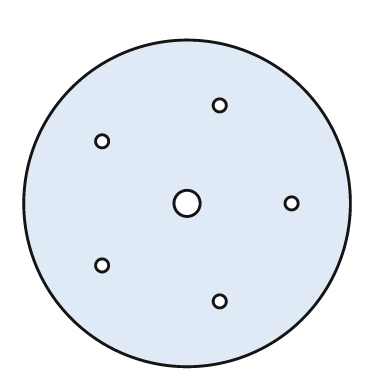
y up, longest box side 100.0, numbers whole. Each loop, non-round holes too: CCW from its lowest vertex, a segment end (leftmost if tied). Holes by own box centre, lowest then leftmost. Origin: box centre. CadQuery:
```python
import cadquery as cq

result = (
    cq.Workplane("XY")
    .moveTo(0.0, 0.0)
    .circle(50.0)
    .moveTo(10.0, -30.0)
    .circle(2.0)
    .moveTo(-26.0, -19.0)
    .circle(2.0)
    .moveTo(0.0, 0.0)
    .circle(4.0)
    .moveTo(32.0, 0.0)
    .circle(2.0)
    .moveTo(-26.0, 19.0)
    .circle(2.0)
    .moveTo(10.0, 30.0)
    .circle(2.0)
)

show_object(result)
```